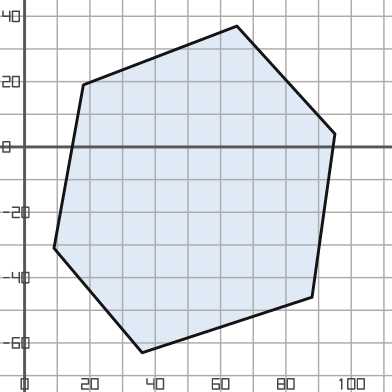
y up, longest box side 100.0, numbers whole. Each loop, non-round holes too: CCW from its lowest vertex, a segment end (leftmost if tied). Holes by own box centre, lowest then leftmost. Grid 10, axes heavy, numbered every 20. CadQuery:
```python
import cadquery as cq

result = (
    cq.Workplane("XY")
    .moveTo(36.0, -63.0)
    .lineTo(88.0, -46.0)
    .lineTo(95.0, 4.0)
    .lineTo(65.0, 37.0)
    .lineTo(18.0, 19.0)
    .lineTo(9.0, -31.0)
    .close()
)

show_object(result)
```